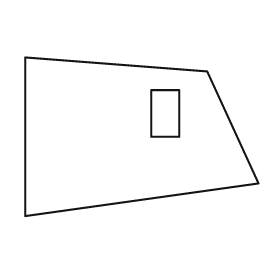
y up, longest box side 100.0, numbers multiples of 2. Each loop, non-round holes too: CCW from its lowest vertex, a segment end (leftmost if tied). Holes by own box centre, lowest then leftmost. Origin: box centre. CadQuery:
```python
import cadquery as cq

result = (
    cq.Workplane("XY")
    .moveTo(-50.0, -34.0)
    .lineTo(50.0, -20.0)
    .lineTo(28.0, 28.0)
    .lineTo(-50.0, 34.0)
    .close()
    .moveTo(4.0, 0.0)
    .lineTo(16.0, 0.0)
    .lineTo(16.0, 20.0)
    .lineTo(4.0, 20.0)
    .close()
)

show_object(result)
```